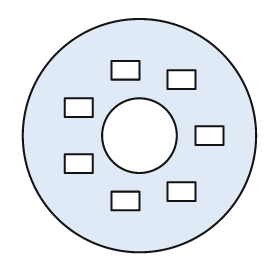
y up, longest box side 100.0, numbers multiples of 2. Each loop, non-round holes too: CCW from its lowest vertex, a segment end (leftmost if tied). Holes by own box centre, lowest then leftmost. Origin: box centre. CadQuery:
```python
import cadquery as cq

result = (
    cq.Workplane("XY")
    .moveTo(0.0, 0.0)
    .circle(50.0)
    .moveTo(-12.0, -32.0)
    .lineTo(0.0, -32.0)
    .lineTo(0.0, -24.0)
    .lineTo(-12.0, -24.0)
    .close()
    .moveTo(12.0, -28.0)
    .lineTo(24.0, -28.0)
    .lineTo(24.0, -20.0)
    .lineTo(12.0, -20.0)
    .close()
    .moveTo(-32.0, -16.0)
    .lineTo(-20.0, -16.0)
    .lineTo(-20.0, -8.0)
    .lineTo(-32.0, -8.0)
    .close()
    .moveTo(0.0, 0.0)
    .circle(16.0)
    .moveTo(24.0, -4.0)
    .lineTo(36.0, -4.0)
    .lineTo(36.0, 4.0)
    .lineTo(24.0, 4.0)
    .close()
    .moveTo(-32.0, 8.0)
    .lineTo(-20.0, 8.0)
    .lineTo(-20.0, 16.0)
    .lineTo(-32.0, 16.0)
    .close()
    .moveTo(12.0, 20.0)
    .lineTo(24.0, 20.0)
    .lineTo(24.0, 28.0)
    .lineTo(12.0, 28.0)
    .close()
    .moveTo(-12.0, 24.0)
    .lineTo(0.0, 24.0)
    .lineTo(0.0, 32.0)
    .lineTo(-12.0, 32.0)
    .close()
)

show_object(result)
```